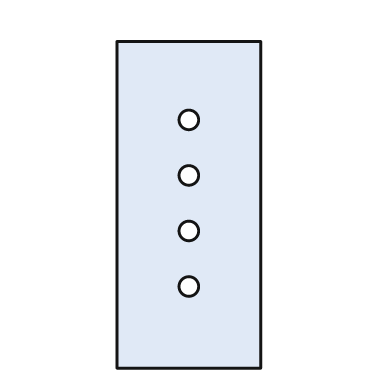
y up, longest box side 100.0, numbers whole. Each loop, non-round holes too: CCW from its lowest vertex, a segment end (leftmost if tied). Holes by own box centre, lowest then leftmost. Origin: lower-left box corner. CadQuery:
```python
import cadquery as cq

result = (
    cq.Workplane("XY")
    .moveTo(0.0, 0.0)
    .lineTo(44.0, 0.0)
    .lineTo(44.0, 100.0)
    .lineTo(0.0, 100.0)
    .close()
    .moveTo(22.0, 25.0)
    .circle(3.0)
    .moveTo(22.0, 42.0)
    .circle(3.0)
    .moveTo(22.0, 59.0)
    .circle(3.0)
    .moveTo(22.0, 76.0)
    .circle(3.0)
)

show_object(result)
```